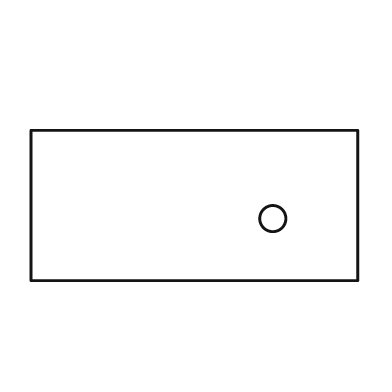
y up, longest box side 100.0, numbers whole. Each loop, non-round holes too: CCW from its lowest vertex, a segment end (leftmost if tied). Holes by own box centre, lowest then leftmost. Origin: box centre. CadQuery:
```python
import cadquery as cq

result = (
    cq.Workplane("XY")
    .moveTo(-50.0, -23.0)
    .lineTo(50.0, -23.0)
    .lineTo(50.0, 23.0)
    .lineTo(-50.0, 23.0)
    .close()
    .moveTo(24.0, -4.0)
    .circle(4.0)
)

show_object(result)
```